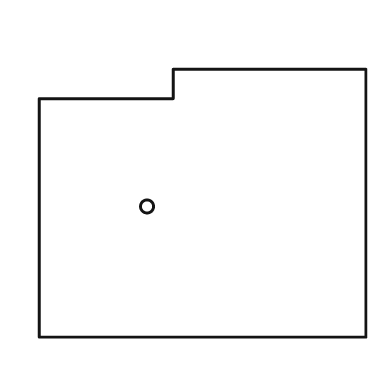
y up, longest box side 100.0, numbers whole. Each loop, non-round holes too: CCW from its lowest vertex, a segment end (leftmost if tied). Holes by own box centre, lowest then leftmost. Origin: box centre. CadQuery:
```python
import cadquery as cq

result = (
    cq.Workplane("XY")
    .moveTo(-50.0, -41.0)
    .lineTo(50.0, -41.0)
    .lineTo(50.0, 41.0)
    .lineTo(-9.0, 41.0)
    .lineTo(-9.0, 32.0)
    .lineTo(-50.0, 32.0)
    .close()
    .moveTo(-17.0, -1.0)
    .circle(2.0)
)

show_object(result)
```